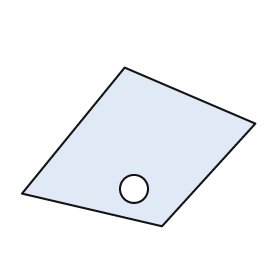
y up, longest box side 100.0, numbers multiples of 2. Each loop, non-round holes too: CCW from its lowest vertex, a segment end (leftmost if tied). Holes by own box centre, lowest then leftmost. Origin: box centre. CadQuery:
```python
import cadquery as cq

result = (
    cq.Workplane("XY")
    .moveTo(10.0, -34.0)
    .lineTo(50.0, 10.0)
    .lineTo(-6.0, 34.0)
    .lineTo(-50.0, -20.0)
    .close()
    .moveTo(-2.0, -18.0)
    .circle(6.0)
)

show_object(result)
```